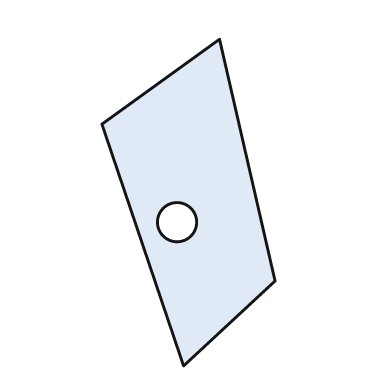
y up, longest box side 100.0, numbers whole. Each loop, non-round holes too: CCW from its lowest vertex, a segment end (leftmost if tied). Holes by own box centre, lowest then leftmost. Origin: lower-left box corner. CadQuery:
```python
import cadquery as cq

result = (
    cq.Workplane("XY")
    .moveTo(25.0, 0.0)
    .lineTo(53.0, 26.0)
    .lineTo(36.0, 100.0)
    .lineTo(0.0, 74.0)
    .close()
    .moveTo(23.0, 44.0)
    .circle(6.0)
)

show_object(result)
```